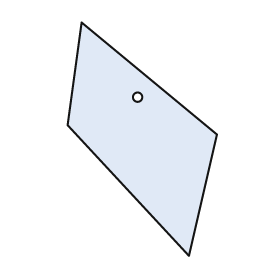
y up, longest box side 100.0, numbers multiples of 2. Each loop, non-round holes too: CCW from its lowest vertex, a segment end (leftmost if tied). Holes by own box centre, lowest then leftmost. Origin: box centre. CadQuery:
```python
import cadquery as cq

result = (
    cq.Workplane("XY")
    .moveTo(20.0, -50.0)
    .lineTo(32.0, 2.0)
    .lineTo(-26.0, 50.0)
    .lineTo(-32.0, 6.0)
    .close()
    .moveTo(-2.0, 18.0)
    .circle(2.0)
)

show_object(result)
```